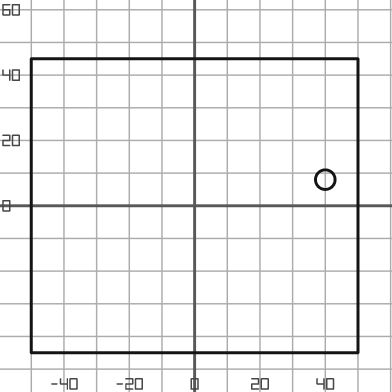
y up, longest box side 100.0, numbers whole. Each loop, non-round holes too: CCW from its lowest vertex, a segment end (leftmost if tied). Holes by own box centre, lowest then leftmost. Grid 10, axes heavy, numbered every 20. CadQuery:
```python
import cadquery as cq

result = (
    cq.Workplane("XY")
    .moveTo(-50.0, -45.0)
    .lineTo(50.0, -45.0)
    .lineTo(50.0, 45.0)
    .lineTo(-50.0, 45.0)
    .close()
    .moveTo(40.0, 8.0)
    .circle(3.0)
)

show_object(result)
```